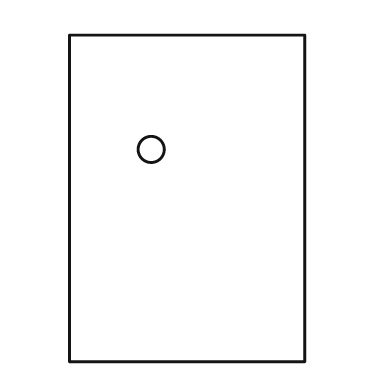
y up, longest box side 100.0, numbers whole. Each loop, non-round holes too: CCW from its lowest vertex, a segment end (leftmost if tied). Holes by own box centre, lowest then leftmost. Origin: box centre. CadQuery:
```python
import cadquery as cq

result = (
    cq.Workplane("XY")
    .moveTo(-36.0, -50.0)
    .lineTo(36.0, -50.0)
    .lineTo(36.0, 50.0)
    .lineTo(-36.0, 50.0)
    .close()
    .moveTo(-11.0, 15.0)
    .circle(4.0)
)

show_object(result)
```